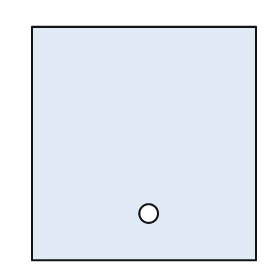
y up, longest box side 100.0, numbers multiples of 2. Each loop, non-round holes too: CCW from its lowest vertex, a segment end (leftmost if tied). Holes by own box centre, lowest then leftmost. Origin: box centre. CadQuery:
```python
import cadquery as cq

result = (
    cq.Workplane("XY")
    .moveTo(-48.0, -50.0)
    .lineTo(48.0, -50.0)
    .lineTo(48.0, 50.0)
    .lineTo(-48.0, 50.0)
    .close()
    .moveTo(2.0, -30.0)
    .circle(4.0)
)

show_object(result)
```